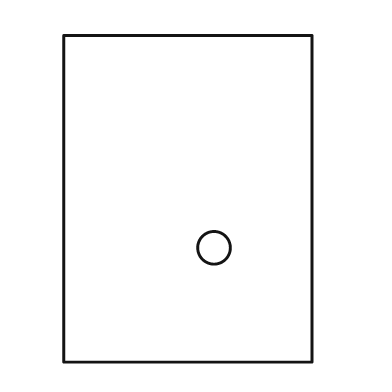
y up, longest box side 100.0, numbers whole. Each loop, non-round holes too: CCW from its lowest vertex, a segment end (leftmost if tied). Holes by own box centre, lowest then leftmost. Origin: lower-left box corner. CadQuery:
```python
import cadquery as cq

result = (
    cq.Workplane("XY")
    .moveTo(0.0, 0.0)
    .lineTo(76.0, 0.0)
    .lineTo(76.0, 100.0)
    .lineTo(0.0, 100.0)
    .close()
    .moveTo(46.0, 35.0)
    .circle(5.0)
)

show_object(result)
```